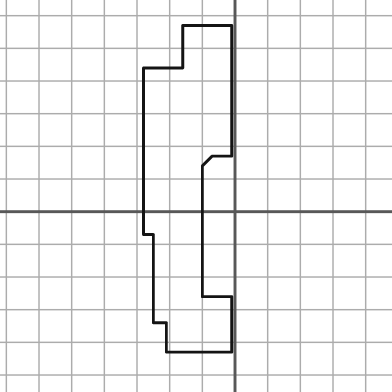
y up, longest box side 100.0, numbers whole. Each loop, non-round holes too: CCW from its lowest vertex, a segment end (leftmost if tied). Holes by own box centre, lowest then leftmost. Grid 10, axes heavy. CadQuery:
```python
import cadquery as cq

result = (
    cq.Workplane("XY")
    .moveTo(-21.0, -43.0)
    .lineTo(-1.0, -43.0)
    .lineTo(-1.0, -26.0)
    .lineTo(-10.0, -26.0)
    .lineTo(-10.0, 14.0)
    .lineTo(-7.0, 17.0)
    .lineTo(-1.0, 17.0)
    .lineTo(-1.0, 57.0)
    .lineTo(-16.0, 57.0)
    .lineTo(-16.0, 44.0)
    .lineTo(-28.0, 44.0)
    .lineTo(-28.0, -7.0)
    .lineTo(-25.0, -7.0)
    .lineTo(-25.0, -34.0)
    .lineTo(-21.0, -34.0)
    .close()
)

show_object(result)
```